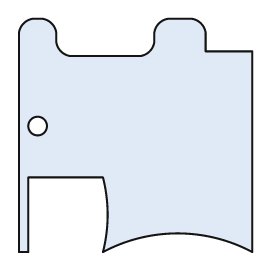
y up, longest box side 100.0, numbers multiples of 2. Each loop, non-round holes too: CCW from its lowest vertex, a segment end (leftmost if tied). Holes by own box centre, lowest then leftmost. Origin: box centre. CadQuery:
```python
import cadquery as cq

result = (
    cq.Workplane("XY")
    .moveTo(-50.0, -50.0)
    .lineTo(-46.0, -50.0)
    .lineTo(-46.0, -18.0)
    .lineTo(-14.0, -18.0)
    .threePointArc((-12.0, -34.0), (-14.0, -50.0))
    .threePointArc((18.0, -42.0), (50.0, -50.0))
    .lineTo(50.0, 36.0)
    .lineTo(30.0, 36.0)
    .lineTo(30.0, 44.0)
    .threePointArc((28.0, 48.0), (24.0, 50.0))
    .lineTo(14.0, 50.0)
    .threePointArc((10.0, 48.0), (8.0, 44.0))
    .lineTo(8.0, 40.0)
    .threePointArc((6.0, 36.0), (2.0, 34.0))
    .lineTo(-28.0, 34.0)
    .threePointArc((-32.0, 36.0), (-34.0, 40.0))
    .lineTo(-34.0, 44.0)
    .threePointArc((-36.0, 48.0), (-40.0, 50.0))
    .lineTo(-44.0, 50.0)
    .threePointArc((-48.0, 48.0), (-50.0, 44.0))
    .close()
    .moveTo(-42.0, 4.0)
    .circle(4.0)
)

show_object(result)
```